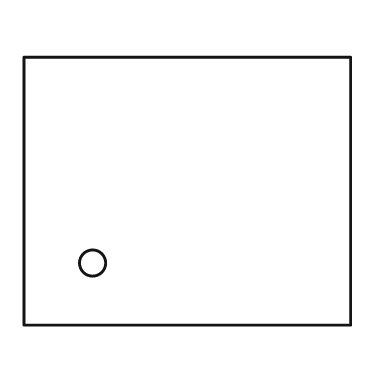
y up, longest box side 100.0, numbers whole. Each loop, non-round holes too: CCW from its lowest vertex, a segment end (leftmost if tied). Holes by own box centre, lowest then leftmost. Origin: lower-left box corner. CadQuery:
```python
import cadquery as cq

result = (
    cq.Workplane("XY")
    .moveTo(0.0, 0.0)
    .lineTo(100.0, 0.0)
    .lineTo(100.0, 82.0)
    .lineTo(0.0, 82.0)
    .close()
    .moveTo(21.0, 19.0)
    .circle(4.0)
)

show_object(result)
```